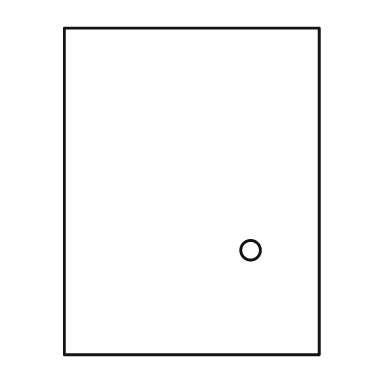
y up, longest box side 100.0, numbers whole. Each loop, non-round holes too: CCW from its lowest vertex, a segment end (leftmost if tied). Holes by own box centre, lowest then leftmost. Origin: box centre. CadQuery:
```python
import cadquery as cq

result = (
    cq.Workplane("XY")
    .moveTo(-39.0, -50.0)
    .lineTo(39.0, -50.0)
    .lineTo(39.0, 50.0)
    .lineTo(-39.0, 50.0)
    .close()
    .moveTo(18.0, -18.0)
    .circle(3.0)
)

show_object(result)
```